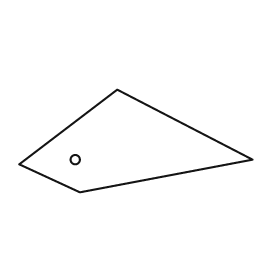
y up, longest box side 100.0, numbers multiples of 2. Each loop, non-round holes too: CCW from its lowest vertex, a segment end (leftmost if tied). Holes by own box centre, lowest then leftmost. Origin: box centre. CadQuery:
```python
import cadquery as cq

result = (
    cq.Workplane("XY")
    .moveTo(-24.0, -22.0)
    .lineTo(50.0, -8.0)
    .lineTo(-8.0, 22.0)
    .lineTo(-50.0, -10.0)
    .close()
    .moveTo(-26.0, -8.0)
    .circle(2.0)
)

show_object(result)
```